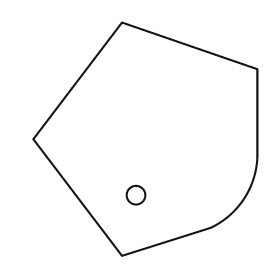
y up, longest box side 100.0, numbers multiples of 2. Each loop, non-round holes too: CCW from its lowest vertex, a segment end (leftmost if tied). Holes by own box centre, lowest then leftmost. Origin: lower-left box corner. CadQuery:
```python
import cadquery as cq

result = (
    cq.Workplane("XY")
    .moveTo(38.0, 0.0)
    .lineTo(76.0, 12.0)
    .threePointArc((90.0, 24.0), (96.0, 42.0))
    .lineTo(96.0, 80.0)
    .lineTo(38.0, 100.0)
    .lineTo(0.0, 50.0)
    .close()
    .moveTo(44.0, 26.0)
    .circle(4.0)
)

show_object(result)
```